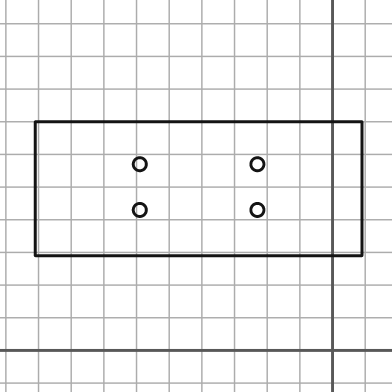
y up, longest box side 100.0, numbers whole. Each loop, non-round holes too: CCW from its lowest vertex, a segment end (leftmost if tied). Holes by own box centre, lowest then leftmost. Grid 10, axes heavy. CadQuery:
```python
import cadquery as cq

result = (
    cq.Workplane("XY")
    .moveTo(-91.0, 29.0)
    .lineTo(9.0, 29.0)
    .lineTo(9.0, 70.0)
    .lineTo(-91.0, 70.0)
    .close()
    .moveTo(-59.0, 43.0)
    .circle(2.0)
    .moveTo(-23.0, 43.0)
    .circle(2.0)
    .moveTo(-59.0, 57.0)
    .circle(2.0)
    .moveTo(-23.0, 57.0)
    .circle(2.0)
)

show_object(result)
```